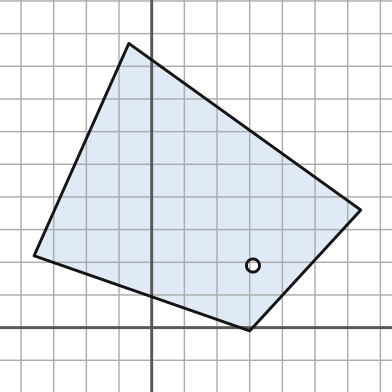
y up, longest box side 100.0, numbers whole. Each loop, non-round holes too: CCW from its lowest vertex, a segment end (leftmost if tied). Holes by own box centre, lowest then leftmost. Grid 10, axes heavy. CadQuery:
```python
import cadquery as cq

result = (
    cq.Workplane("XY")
    .moveTo(30.0, -1.0)
    .lineTo(64.0, 36.0)
    .lineTo(-7.0, 87.0)
    .lineTo(-36.0, 22.0)
    .close()
    .moveTo(31.0, 19.0)
    .circle(2.0)
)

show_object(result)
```